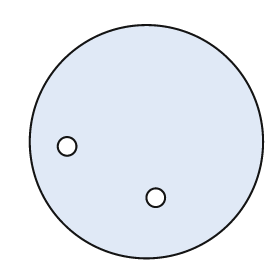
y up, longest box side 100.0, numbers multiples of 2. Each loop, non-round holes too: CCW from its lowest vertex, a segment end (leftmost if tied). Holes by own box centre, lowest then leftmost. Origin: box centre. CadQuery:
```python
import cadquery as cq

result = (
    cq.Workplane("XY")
    .moveTo(0.0, 0.0)
    .circle(50.0)
    .moveTo(4.0, -24.0)
    .circle(4.0)
    .moveTo(-34.0, -2.0)
    .circle(4.0)
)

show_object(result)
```